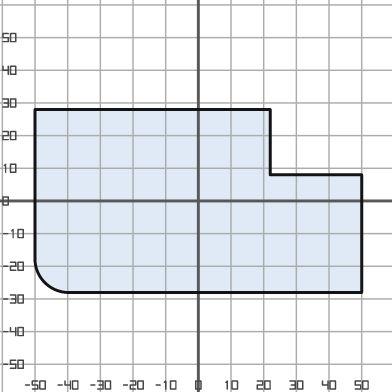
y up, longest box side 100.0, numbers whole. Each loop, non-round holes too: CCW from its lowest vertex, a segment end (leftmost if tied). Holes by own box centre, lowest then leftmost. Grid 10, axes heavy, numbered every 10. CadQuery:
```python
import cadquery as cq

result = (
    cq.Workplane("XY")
    .moveTo(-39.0, -28.0)
    .lineTo(50.0, -28.0)
    .lineTo(50.0, 8.0)
    .lineTo(22.0, 8.0)
    .lineTo(22.0, 28.0)
    .lineTo(-50.0, 28.0)
    .lineTo(-50.0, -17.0)
    .threePointArc((-47.0, -25.0), (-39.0, -28.0))
    .close()
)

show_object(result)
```